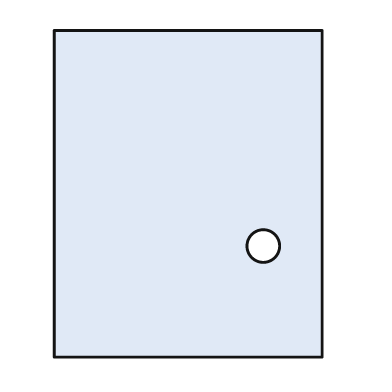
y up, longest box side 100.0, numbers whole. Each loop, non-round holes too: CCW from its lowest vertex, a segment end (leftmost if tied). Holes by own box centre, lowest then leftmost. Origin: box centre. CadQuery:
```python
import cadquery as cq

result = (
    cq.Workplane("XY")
    .moveTo(-41.0, -50.0)
    .lineTo(41.0, -50.0)
    .lineTo(41.0, 50.0)
    .lineTo(-41.0, 50.0)
    .close()
    .moveTo(23.0, -16.0)
    .circle(5.0)
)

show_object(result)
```